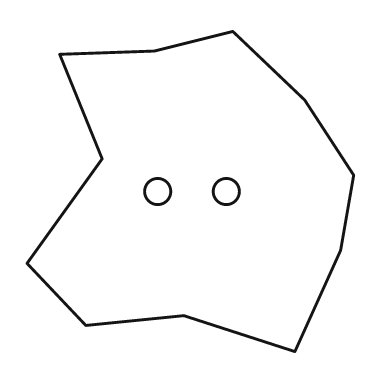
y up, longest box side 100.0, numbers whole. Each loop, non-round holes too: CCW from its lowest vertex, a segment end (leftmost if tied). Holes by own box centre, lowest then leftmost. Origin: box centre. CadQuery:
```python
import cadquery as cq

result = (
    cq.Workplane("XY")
    .moveTo(32.0, -49.0)
    .lineTo(46.0, -18.0)
    .lineTo(50.0, 5.0)
    .lineTo(35.0, 28.0)
    .lineTo(13.0, 49.0)
    .lineTo(-11.0, 43.0)
    .lineTo(-40.0, 42.0)
    .lineTo(-27.0, 10.0)
    .lineTo(-50.0, -22.0)
    .lineTo(-32.0, -41.0)
    .lineTo(-2.0, -38.0)
    .close()
    .moveTo(-10.0, 0.0)
    .circle(4.0)
    .moveTo(11.0, 0.0)
    .circle(4.0)
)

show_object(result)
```